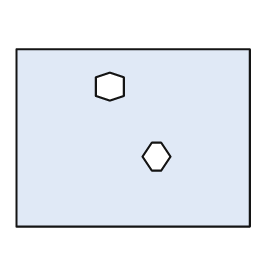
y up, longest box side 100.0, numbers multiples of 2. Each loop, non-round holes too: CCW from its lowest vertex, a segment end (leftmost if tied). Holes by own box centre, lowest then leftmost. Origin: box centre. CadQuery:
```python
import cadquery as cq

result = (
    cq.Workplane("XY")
    .moveTo(-50.0, -38.0)
    .lineTo(50.0, -38.0)
    .lineTo(50.0, 38.0)
    .lineTo(-50.0, 38.0)
    .close()
    .moveTo(8.0, -14.0)
    .lineTo(12.0, -14.0)
    .lineTo(16.0, -8.0)
    .lineTo(12.0, -2.0)
    .lineTo(8.0, -2.0)
    .lineTo(4.0, -8.0)
    .close()
    .moveTo(-10.0, 16.0)
    .lineTo(-4.0, 18.0)
    .lineTo(-4.0, 26.0)
    .lineTo(-10.0, 28.0)
    .lineTo(-16.0, 26.0)
    .lineTo(-16.0, 18.0)
    .close()
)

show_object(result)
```